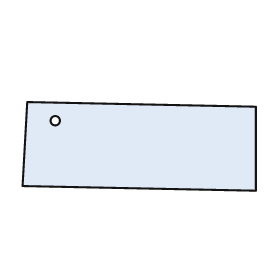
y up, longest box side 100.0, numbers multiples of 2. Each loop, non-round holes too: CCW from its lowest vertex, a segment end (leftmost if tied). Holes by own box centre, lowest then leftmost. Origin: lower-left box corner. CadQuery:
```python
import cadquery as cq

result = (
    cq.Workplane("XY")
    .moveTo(100.0, 0.0)
    .lineTo(100.0, 36.0)
    .lineTo(2.0, 38.0)
    .lineTo(0.0, 2.0)
    .close()
    .moveTo(14.0, 30.0)
    .circle(2.0)
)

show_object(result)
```